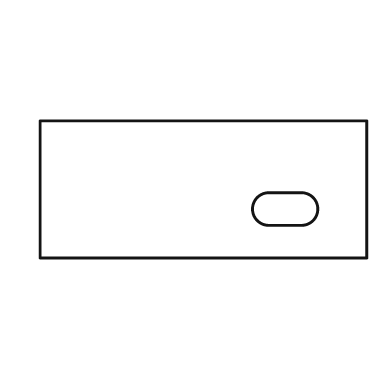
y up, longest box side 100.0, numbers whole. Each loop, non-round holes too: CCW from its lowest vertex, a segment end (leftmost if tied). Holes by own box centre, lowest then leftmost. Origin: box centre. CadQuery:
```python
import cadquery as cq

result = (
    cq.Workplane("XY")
    .moveTo(-50.0, -21.0)
    .lineTo(50.0, -21.0)
    .lineTo(50.0, 21.0)
    .lineTo(-50.0, 21.0)
    .close()
    .moveTo(20.0, -11.0)
    .lineTo(30.0, -11.0)
    .threePointArc((35.0, -6.0), (30.0, -1.0))
    .lineTo(20.0, -1.0)
    .threePointArc((15.0, -6.0), (20.0, -11.0))
    .close()
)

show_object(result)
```